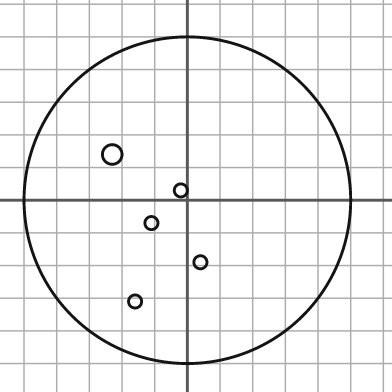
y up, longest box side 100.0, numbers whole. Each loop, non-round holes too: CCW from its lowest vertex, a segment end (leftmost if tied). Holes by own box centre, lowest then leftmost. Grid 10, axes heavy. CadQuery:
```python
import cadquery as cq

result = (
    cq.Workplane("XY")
    .moveTo(0.0, 0.0)
    .circle(50.0)
    .moveTo(-16.0, -31.0)
    .circle(2.0)
    .moveTo(4.0, -19.0)
    .circle(2.0)
    .moveTo(-11.0, -7.0)
    .circle(2.0)
    .moveTo(-2.0, 3.0)
    .circle(2.0)
    .moveTo(-23.0, 14.0)
    .circle(3.0)
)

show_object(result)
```